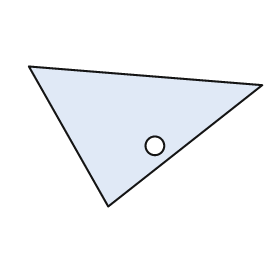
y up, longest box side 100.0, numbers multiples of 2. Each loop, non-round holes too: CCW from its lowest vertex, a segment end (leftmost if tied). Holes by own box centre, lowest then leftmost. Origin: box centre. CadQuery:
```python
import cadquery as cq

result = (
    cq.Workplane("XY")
    .moveTo(-16.0, -30.0)
    .lineTo(50.0, 22.0)
    .lineTo(-50.0, 30.0)
    .close()
    .moveTo(4.0, -4.0)
    .circle(4.0)
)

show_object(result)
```